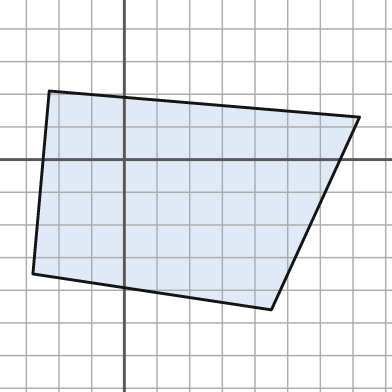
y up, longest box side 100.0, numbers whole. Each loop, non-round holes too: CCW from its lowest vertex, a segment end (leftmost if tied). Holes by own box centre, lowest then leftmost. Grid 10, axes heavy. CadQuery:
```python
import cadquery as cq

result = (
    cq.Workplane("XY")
    .moveTo(45.0, -46.0)
    .lineTo(72.0, 13.0)
    .lineTo(-23.0, 21.0)
    .lineTo(-28.0, -35.0)
    .close()
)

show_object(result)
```